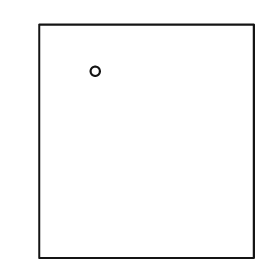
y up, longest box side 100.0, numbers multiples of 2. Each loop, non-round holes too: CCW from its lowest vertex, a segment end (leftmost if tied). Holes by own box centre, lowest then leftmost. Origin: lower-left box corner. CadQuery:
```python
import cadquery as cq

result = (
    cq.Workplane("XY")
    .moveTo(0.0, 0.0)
    .lineTo(92.0, 0.0)
    .lineTo(92.0, 100.0)
    .lineTo(0.0, 100.0)
    .close()
    .moveTo(24.0, 80.0)
    .circle(2.0)
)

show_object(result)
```